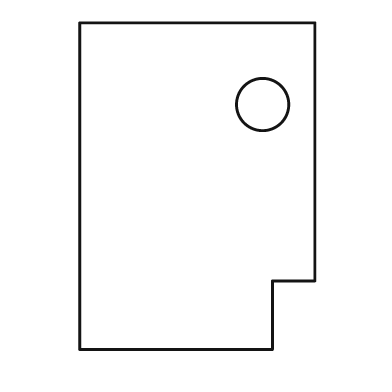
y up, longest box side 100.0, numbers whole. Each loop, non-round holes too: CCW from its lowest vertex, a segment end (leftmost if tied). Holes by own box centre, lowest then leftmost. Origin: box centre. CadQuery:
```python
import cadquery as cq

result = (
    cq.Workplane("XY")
    .moveTo(-36.0, -50.0)
    .lineTo(23.0, -50.0)
    .lineTo(23.0, -29.0)
    .lineTo(36.0, -29.0)
    .lineTo(36.0, 50.0)
    .lineTo(-36.0, 50.0)
    .close()
    .moveTo(20.0, 25.0)
    .circle(8.0)
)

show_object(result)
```